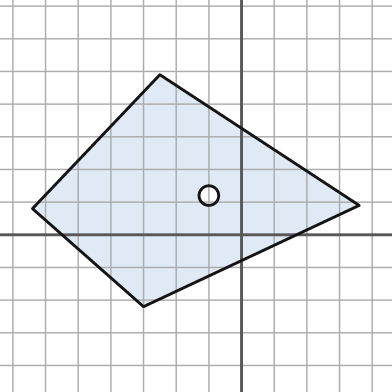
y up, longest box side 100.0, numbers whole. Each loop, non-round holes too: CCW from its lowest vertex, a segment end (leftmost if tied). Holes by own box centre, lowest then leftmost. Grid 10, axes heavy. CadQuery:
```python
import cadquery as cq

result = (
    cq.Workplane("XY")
    .moveTo(-30.0, -22.0)
    .lineTo(36.0, 9.0)
    .lineTo(-25.0, 49.0)
    .lineTo(-64.0, 8.0)
    .close()
    .moveTo(-10.0, 12.0)
    .circle(3.0)
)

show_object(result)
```